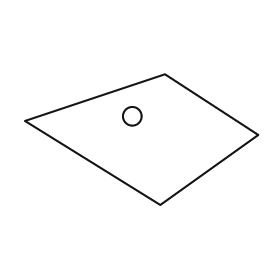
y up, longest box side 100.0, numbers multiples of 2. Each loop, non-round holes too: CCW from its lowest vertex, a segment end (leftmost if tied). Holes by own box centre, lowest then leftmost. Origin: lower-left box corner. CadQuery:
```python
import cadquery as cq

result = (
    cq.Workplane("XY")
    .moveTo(58.0, 0.0)
    .lineTo(100.0, 30.0)
    .lineTo(60.0, 56.0)
    .lineTo(0.0, 36.0)
    .close()
    .moveTo(46.0, 38.0)
    .circle(4.0)
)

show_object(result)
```